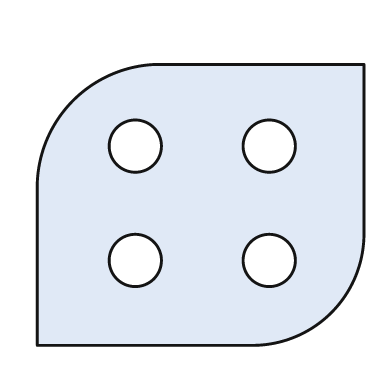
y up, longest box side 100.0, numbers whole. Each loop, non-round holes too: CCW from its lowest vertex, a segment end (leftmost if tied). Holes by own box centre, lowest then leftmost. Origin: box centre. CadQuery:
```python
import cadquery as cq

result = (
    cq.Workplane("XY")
    .moveTo(-50.0, -43.0)
    .lineTo(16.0, -43.0)
    .threePointArc((40.0, -33.0), (50.0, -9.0))
    .lineTo(50.0, 43.0)
    .lineTo(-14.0, 43.0)
    .threePointArc((-39.0, 32.0), (-50.0, 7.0))
    .close()
    .moveTo(-20.0, -17.0)
    .circle(8.0)
    .moveTo(21.0, -17.0)
    .circle(8.0)
    .moveTo(-20.0, 18.0)
    .circle(8.0)
    .moveTo(21.0, 18.0)
    .circle(8.0)
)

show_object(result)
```